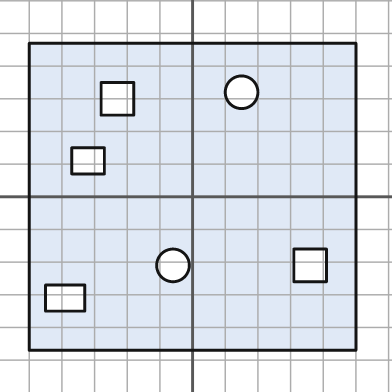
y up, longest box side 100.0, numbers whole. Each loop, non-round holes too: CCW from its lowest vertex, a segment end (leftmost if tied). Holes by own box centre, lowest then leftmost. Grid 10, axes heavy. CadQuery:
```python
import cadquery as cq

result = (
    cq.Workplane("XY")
    .moveTo(-50.0, -47.0)
    .lineTo(50.0, -47.0)
    .lineTo(50.0, 47.0)
    .lineTo(-50.0, 47.0)
    .close()
    .moveTo(-45.0, -35.0)
    .lineTo(-33.0, -35.0)
    .lineTo(-33.0, -27.0)
    .lineTo(-45.0, -27.0)
    .close()
    .moveTo(-6.0, -21.0)
    .circle(5.0)
    .moveTo(31.0, -26.0)
    .lineTo(41.0, -26.0)
    .lineTo(41.0, -16.0)
    .lineTo(31.0, -16.0)
    .close()
    .moveTo(-37.0, 7.0)
    .lineTo(-27.0, 7.0)
    .lineTo(-27.0, 15.0)
    .lineTo(-37.0, 15.0)
    .close()
    .moveTo(-28.0, 25.0)
    .lineTo(-18.0, 25.0)
    .lineTo(-18.0, 35.0)
    .lineTo(-28.0, 35.0)
    .close()
    .moveTo(15.0, 32.0)
    .circle(5.0)
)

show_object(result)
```